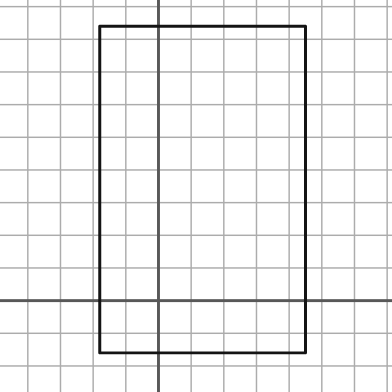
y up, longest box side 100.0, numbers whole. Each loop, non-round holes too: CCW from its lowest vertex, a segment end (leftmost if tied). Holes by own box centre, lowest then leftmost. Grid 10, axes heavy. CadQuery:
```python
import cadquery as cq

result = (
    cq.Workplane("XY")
    .moveTo(-18.0, -16.0)
    .lineTo(45.0, -16.0)
    .lineTo(45.0, 84.0)
    .lineTo(-18.0, 84.0)
    .close()
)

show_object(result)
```